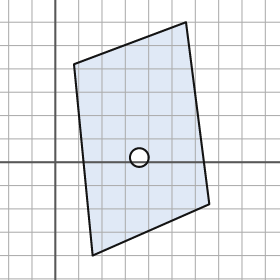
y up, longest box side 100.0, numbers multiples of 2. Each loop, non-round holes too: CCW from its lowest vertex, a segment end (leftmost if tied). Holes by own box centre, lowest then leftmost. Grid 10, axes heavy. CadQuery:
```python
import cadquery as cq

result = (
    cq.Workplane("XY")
    .moveTo(16.0, -40.0)
    .lineTo(66.0, -18.0)
    .lineTo(56.0, 60.0)
    .lineTo(8.0, 42.0)
    .close()
    .moveTo(36.0, 2.0)
    .circle(4.0)
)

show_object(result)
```